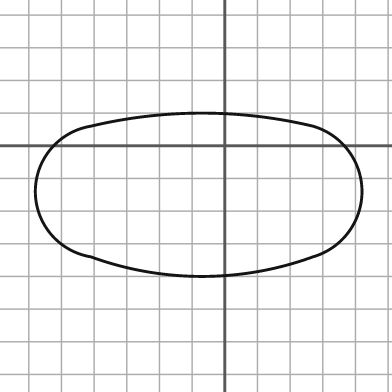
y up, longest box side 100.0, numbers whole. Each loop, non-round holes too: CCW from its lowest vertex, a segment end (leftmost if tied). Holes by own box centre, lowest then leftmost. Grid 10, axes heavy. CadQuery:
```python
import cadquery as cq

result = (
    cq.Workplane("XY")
    .moveTo(-41.0, -34.0)
    .threePointArc((-7.0, -40.0), (27.0, -34.0))
    .threePointArc((42.0, -14.0), (27.0, 6.0))
    .threePointArc((-7.0, 10.0), (-41.0, 6.0))
    .threePointArc((-58.0, -14.0), (-41.0, -34.0))
    .close()
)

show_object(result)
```